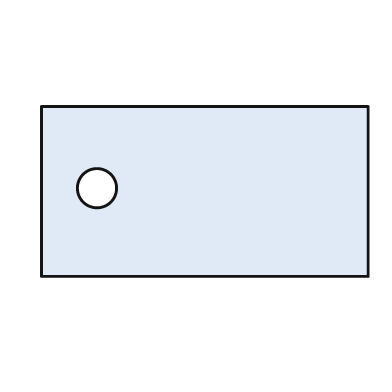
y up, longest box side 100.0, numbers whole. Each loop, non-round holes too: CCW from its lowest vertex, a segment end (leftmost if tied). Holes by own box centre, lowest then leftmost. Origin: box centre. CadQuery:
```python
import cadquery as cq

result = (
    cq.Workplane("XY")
    .moveTo(-50.0, -26.0)
    .lineTo(50.0, -26.0)
    .lineTo(50.0, 26.0)
    .lineTo(-50.0, 26.0)
    .close()
    .moveTo(-33.0, 1.0)
    .circle(6.0)
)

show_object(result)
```